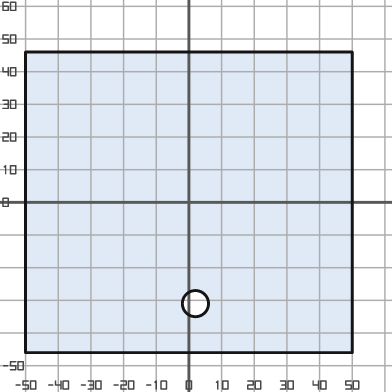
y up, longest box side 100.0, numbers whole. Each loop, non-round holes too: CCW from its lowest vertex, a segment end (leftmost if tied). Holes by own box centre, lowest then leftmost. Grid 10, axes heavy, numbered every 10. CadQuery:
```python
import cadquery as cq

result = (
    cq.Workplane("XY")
    .moveTo(-50.0, -46.0)
    .lineTo(50.0, -46.0)
    .lineTo(50.0, 46.0)
    .lineTo(-50.0, 46.0)
    .close()
    .moveTo(2.0, -31.0)
    .circle(4.0)
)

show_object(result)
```